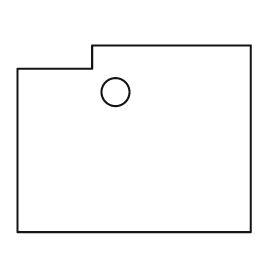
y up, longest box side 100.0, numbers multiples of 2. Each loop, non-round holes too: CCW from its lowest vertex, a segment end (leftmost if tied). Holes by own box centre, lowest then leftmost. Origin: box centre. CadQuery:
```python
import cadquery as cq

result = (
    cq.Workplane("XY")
    .moveTo(-50.0, -40.0)
    .lineTo(50.0, -40.0)
    .lineTo(50.0, 40.0)
    .lineTo(-18.0, 40.0)
    .lineTo(-18.0, 30.0)
    .lineTo(-50.0, 30.0)
    .close()
    .moveTo(-8.0, 20.0)
    .circle(6.0)
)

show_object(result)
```